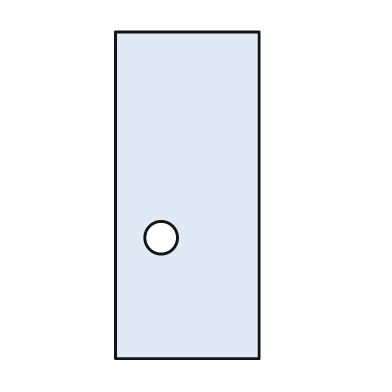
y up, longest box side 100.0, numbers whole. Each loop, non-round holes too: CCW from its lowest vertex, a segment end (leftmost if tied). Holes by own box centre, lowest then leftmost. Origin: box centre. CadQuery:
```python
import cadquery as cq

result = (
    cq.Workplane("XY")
    .moveTo(-22.0, -50.0)
    .lineTo(22.0, -50.0)
    .lineTo(22.0, 50.0)
    .lineTo(-22.0, 50.0)
    .close()
    .moveTo(-8.0, -13.0)
    .circle(5.0)
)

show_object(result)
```